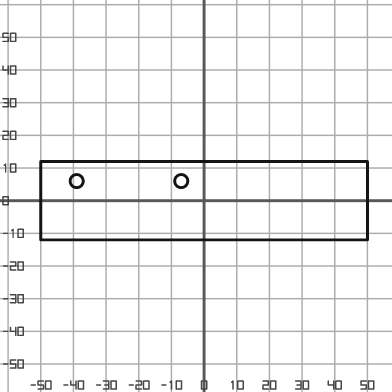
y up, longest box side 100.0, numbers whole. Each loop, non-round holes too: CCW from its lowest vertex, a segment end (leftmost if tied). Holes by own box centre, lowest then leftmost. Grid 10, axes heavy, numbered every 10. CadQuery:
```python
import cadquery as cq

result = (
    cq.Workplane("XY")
    .moveTo(-50.0, -12.0)
    .lineTo(50.0, -12.0)
    .lineTo(50.0, 12.0)
    .lineTo(-50.0, 12.0)
    .close()
    .moveTo(-39.0, 6.0)
    .circle(2.0)
    .moveTo(-7.0, 6.0)
    .circle(2.0)
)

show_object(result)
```